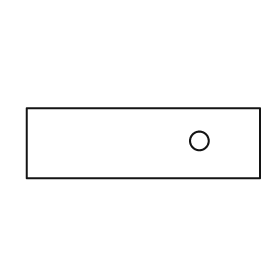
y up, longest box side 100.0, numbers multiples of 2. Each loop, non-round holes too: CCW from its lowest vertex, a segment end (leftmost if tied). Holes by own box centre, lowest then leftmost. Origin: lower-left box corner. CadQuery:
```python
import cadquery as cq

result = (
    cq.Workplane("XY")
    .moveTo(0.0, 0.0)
    .lineTo(100.0, 0.0)
    .lineTo(100.0, 30.0)
    .lineTo(0.0, 30.0)
    .close()
    .moveTo(74.0, 16.0)
    .circle(4.0)
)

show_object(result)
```